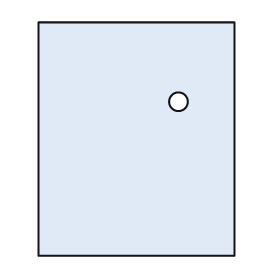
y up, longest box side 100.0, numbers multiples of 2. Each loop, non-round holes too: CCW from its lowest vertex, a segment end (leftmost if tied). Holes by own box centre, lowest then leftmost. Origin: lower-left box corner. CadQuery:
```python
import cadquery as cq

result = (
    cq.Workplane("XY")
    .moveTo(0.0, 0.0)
    .lineTo(84.0, 0.0)
    .lineTo(84.0, 100.0)
    .lineTo(0.0, 100.0)
    .close()
    .moveTo(60.0, 66.0)
    .circle(4.0)
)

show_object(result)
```